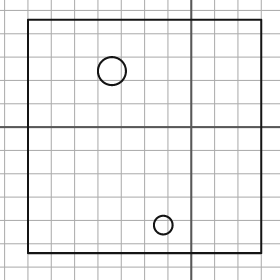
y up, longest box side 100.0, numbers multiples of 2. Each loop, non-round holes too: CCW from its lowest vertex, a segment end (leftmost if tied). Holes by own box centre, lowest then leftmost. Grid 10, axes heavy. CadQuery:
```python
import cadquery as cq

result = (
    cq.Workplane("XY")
    .moveTo(-70.0, -54.0)
    .lineTo(30.0, -54.0)
    .lineTo(30.0, 46.0)
    .lineTo(-70.0, 46.0)
    .close()
    .moveTo(-12.0, -42.0)
    .circle(4.0)
    .moveTo(-34.0, 24.0)
    .circle(6.0)
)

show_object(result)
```